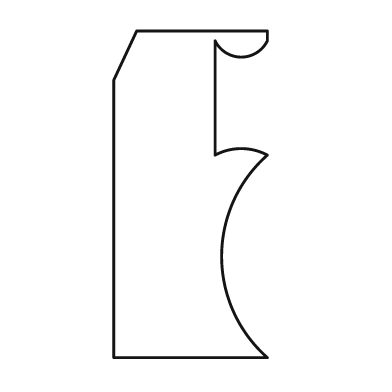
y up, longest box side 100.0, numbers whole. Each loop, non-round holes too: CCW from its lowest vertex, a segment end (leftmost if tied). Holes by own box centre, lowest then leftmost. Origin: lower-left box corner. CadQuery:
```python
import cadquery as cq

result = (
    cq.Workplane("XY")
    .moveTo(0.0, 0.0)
    .lineTo(47.0, 0.0)
    .threePointArc((33.0, 31.0), (47.0, 62.0))
    .threePointArc((39.0, 64.0), (31.0, 62.0))
    .lineTo(31.0, 97.0)
    .threePointArc((39.0, 92.0), (47.0, 97.0))
    .lineTo(47.0, 100.0)
    .lineTo(7.0, 100.0)
    .lineTo(0.0, 85.0)
    .close()
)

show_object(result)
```